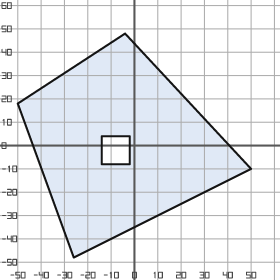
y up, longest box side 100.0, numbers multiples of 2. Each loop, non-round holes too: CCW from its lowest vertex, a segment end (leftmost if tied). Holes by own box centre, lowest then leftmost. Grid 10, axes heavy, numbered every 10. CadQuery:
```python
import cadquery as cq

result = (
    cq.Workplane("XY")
    .moveTo(-26.0, -48.0)
    .lineTo(50.0, -10.0)
    .lineTo(-4.0, 48.0)
    .lineTo(-50.0, 18.0)
    .close()
    .moveTo(-14.0, -8.0)
    .lineTo(-2.0, -8.0)
    .lineTo(-2.0, 4.0)
    .lineTo(-14.0, 4.0)
    .close()
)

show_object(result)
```